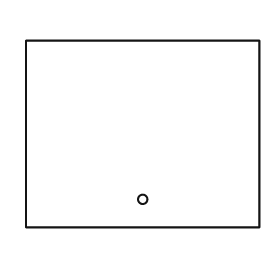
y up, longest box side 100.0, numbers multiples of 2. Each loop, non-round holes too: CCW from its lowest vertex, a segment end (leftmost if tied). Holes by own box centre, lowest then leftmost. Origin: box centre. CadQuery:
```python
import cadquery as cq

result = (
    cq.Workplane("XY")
    .moveTo(-50.0, -40.0)
    .lineTo(50.0, -40.0)
    .lineTo(50.0, 40.0)
    .lineTo(-50.0, 40.0)
    .close()
    .moveTo(0.0, -28.0)
    .circle(2.0)
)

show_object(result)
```